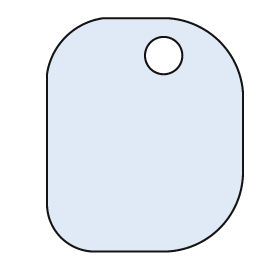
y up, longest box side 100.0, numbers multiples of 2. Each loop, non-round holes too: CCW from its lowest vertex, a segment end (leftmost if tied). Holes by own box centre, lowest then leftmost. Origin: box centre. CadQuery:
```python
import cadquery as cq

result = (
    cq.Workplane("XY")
    .moveTo(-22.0, -50.0)
    .lineTo(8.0, -50.0)
    .threePointArc((32.0, -40.0), (42.0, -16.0))
    .lineTo(42.0, 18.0)
    .threePointArc((32.0, 40.0), (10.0, 50.0))
    .lineTo(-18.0, 50.0)
    .threePointArc((-34.0, 42.0), (-42.0, 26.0))
    .lineTo(-42.0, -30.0)
    .threePointArc((-36.0, -44.0), (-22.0, -50.0))
    .close()
    .moveTo(8.0, 34.0)
    .circle(8.0)
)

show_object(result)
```